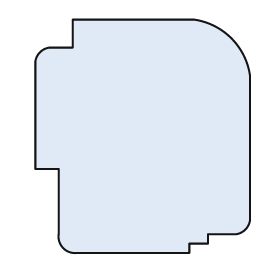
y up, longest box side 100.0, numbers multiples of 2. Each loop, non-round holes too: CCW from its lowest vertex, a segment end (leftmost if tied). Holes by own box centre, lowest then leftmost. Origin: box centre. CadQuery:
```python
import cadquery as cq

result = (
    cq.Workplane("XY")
    .moveTo(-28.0, -50.0)
    .lineTo(20.0, -50.0)
    .lineTo(20.0, -46.0)
    .lineTo(28.0, -46.0)
    .lineTo(28.0, -42.0)
    .lineTo(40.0, -42.0)
    .threePointArc((44.0, -40.0), (46.0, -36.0))
    .lineTo(46.0, 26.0)
    .threePointArc((38.0, 42.0), (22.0, 50.0))
    .lineTo(-30.0, 50.0)
    .lineTo(-30.0, 38.0)
    .lineTo(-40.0, 38.0)
    .threePointArc((-44.0, 36.0), (-46.0, 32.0))
    .lineTo(-46.0, -14.0)
    .lineTo(-36.0, -14.0)
    .lineTo(-36.0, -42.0)
    .threePointArc((-34.0, -48.0), (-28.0, -50.0))
    .close()
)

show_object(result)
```